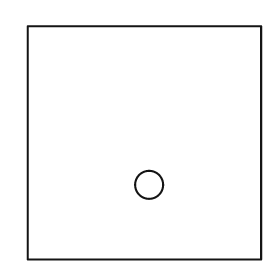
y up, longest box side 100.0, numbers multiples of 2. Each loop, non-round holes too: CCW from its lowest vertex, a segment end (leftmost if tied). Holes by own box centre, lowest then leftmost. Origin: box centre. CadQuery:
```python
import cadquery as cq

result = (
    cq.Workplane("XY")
    .moveTo(-50.0, -50.0)
    .lineTo(50.0, -50.0)
    .lineTo(50.0, 50.0)
    .lineTo(-50.0, 50.0)
    .close()
    .moveTo(2.0, -18.0)
    .circle(6.0)
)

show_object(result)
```